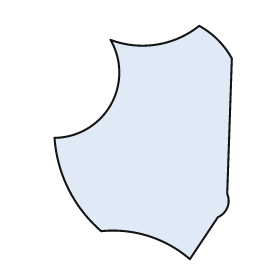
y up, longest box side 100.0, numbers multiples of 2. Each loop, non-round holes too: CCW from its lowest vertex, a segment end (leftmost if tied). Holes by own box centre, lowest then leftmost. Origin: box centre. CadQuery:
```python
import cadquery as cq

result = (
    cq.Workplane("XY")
    .moveTo(20.0, -50.0)
    .lineTo(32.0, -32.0)
    .threePointArc((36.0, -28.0), (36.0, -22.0))
    .lineTo(38.0, 36.0)
    .threePointArc((32.0, 44.0), (24.0, 50.0))
    .threePointArc((6.0, 42.0), (-14.0, 44.0))
    .threePointArc((-14.0, 16.0), (-38.0, 2.0))
    .threePointArc((-32.0, -20.0), (-18.0, -38.0))
    .threePointArc((2.0, -40.0), (20.0, -50.0))
    .close()
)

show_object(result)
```